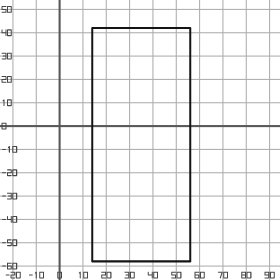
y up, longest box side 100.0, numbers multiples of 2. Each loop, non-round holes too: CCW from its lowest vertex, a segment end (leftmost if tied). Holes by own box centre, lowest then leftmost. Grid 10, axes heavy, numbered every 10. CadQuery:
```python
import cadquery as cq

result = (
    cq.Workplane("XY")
    .moveTo(14.0, -58.0)
    .lineTo(56.0, -58.0)
    .lineTo(56.0, 42.0)
    .lineTo(14.0, 42.0)
    .close()
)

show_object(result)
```